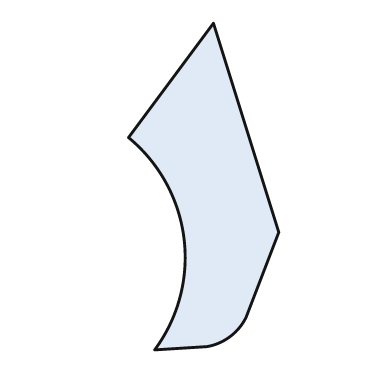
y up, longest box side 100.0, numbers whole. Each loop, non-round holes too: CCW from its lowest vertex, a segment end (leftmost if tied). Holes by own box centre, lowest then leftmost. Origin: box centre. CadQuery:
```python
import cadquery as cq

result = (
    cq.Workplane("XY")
    .moveTo(-15.0, -50.0)
    .lineTo(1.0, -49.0)
    .threePointArc((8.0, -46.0), (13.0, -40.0))
    .lineTo(23.0, -14.0)
    .lineTo(3.0, 50.0)
    .lineTo(-23.0, 15.0)
    .threePointArc((-6.0, -16.0), (-15.0, -50.0))
    .close()
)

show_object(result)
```